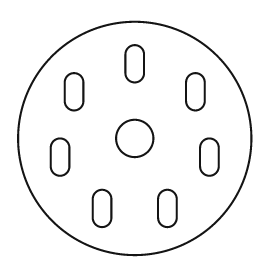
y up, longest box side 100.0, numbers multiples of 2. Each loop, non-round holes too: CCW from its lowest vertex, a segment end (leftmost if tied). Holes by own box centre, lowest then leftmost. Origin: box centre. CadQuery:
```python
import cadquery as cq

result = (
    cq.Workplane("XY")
    .moveTo(0.0, 0.0)
    .circle(50.0)
    .moveTo(-18.0, -34.0)
    .threePointArc((-14.0, -38.0), (-10.0, -34.0))
    .lineTo(-10.0, -26.0)
    .threePointArc((-14.0, -22.0), (-18.0, -26.0))
    .close()
    .moveTo(10.0, -34.0)
    .threePointArc((14.0, -38.0), (18.0, -34.0))
    .lineTo(18.0, -26.0)
    .threePointArc((14.0, -22.0), (10.0, -26.0))
    .close()
    .moveTo(-36.0, -12.0)
    .threePointArc((-32.0, -16.0), (-28.0, -12.0))
    .lineTo(-28.0, -4.0)
    .threePointArc((-32.0, 0.0), (-36.0, -4.0))
    .close()
    .moveTo(28.0, -12.0)
    .threePointArc((32.0, -16.0), (36.0, -12.0))
    .lineTo(36.0, -4.0)
    .threePointArc((32.0, 0.0), (28.0, -4.0))
    .close()
    .moveTo(0.0, 0.0)
    .circle(8.0)
    .moveTo(-30.0, 16.0)
    .threePointArc((-26.0, 12.0), (-22.0, 16.0))
    .lineTo(-22.0, 24.0)
    .threePointArc((-26.0, 28.0), (-30.0, 24.0))
    .close()
    .moveTo(22.0, 16.0)
    .threePointArc((26.0, 12.0), (30.0, 16.0))
    .lineTo(30.0, 24.0)
    .threePointArc((26.0, 28.0), (22.0, 24.0))
    .close()
    .moveTo(-4.0, 28.0)
    .threePointArc((0.0, 24.0), (4.0, 28.0))
    .lineTo(4.0, 36.0)
    .threePointArc((0.0, 40.0), (-4.0, 36.0))
    .close()
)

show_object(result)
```